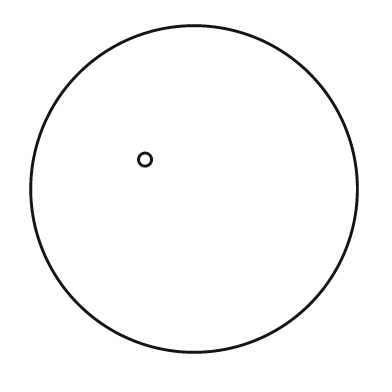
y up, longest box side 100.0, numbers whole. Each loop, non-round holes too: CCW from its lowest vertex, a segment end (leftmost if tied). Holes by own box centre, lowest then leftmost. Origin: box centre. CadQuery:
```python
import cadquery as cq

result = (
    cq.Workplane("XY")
    .moveTo(0.0, 0.0)
    .circle(50.0)
    .moveTo(-15.0, 9.0)
    .circle(2.0)
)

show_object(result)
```